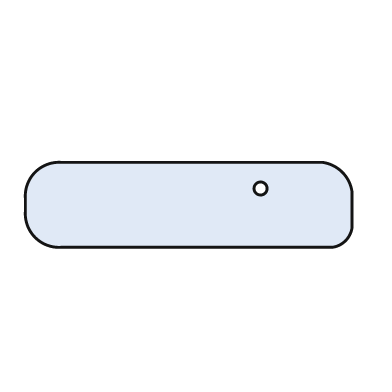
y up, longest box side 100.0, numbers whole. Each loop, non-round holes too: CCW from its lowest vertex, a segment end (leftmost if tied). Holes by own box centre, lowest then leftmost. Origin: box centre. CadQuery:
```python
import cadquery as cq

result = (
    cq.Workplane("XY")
    .moveTo(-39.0, -13.0)
    .lineTo(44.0, -13.0)
    .threePointArc((48.0, -11.0), (50.0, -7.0))
    .lineTo(50.0, 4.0)
    .threePointArc((47.0, 10.0), (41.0, 13.0))
    .lineTo(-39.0, 13.0)
    .threePointArc((-47.0, 10.0), (-50.0, 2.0))
    .lineTo(-50.0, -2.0)
    .threePointArc((-47.0, -10.0), (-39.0, -13.0))
    .close()
    .moveTo(22.0, 5.0)
    .circle(2.0)
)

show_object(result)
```